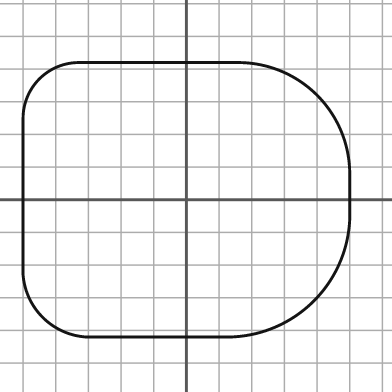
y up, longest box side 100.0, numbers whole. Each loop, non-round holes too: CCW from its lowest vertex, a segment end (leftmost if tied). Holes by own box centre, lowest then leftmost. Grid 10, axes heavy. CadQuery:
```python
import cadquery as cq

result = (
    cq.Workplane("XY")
    .moveTo(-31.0, -42.0)
    .lineTo(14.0, -42.0)
    .threePointArc((39.0, -31.0), (50.0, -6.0))
    .lineTo(50.0, 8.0)
    .threePointArc((40.0, 32.0), (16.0, 42.0))
    .lineTo(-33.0, 42.0)
    .threePointArc((-45.0, 37.0), (-50.0, 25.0))
    .lineTo(-50.0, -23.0)
    .threePointArc((-44.0, -36.0), (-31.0, -42.0))
    .close()
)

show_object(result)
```